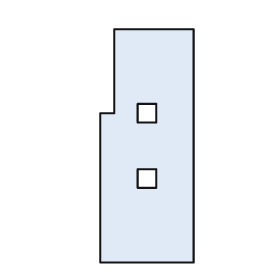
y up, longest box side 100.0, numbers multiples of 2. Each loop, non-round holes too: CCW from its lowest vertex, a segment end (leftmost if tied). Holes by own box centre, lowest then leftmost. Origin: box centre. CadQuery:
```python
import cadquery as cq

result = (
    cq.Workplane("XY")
    .moveTo(-20.0, -50.0)
    .lineTo(20.0, -50.0)
    .lineTo(20.0, 50.0)
    .lineTo(-14.0, 50.0)
    .lineTo(-14.0, 14.0)
    .lineTo(-20.0, 14.0)
    .close()
    .moveTo(-4.0, -18.0)
    .lineTo(4.0, -18.0)
    .lineTo(4.0, -10.0)
    .lineTo(-4.0, -10.0)
    .close()
    .moveTo(-4.0, 10.0)
    .lineTo(4.0, 10.0)
    .lineTo(4.0, 18.0)
    .lineTo(-4.0, 18.0)
    .close()
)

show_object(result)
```